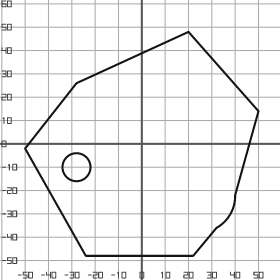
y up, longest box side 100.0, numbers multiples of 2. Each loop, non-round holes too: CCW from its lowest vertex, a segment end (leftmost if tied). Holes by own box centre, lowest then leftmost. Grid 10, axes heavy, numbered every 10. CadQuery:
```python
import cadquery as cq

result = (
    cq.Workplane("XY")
    .moveTo(-24.0, -48.0)
    .lineTo(22.0, -48.0)
    .lineTo(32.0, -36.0)
    .threePointArc((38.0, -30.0), (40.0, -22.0))
    .lineTo(50.0, 14.0)
    .lineTo(20.0, 48.0)
    .lineTo(-28.0, 26.0)
    .lineTo(-50.0, -2.0)
    .close()
    .moveTo(-28.0, -10.0)
    .circle(6.0)
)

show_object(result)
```